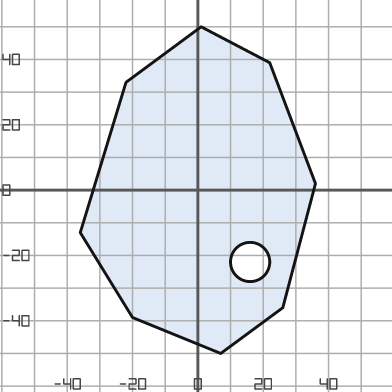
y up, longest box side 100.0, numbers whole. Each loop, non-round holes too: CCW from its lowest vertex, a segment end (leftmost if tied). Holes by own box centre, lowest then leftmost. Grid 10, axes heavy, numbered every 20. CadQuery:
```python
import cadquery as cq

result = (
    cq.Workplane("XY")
    .moveTo(7.0, -50.0)
    .lineTo(26.0, -36.0)
    .lineTo(36.0, 2.0)
    .lineTo(22.0, 39.0)
    .lineTo(1.0, 50.0)
    .lineTo(-22.0, 33.0)
    .lineTo(-36.0, -13.0)
    .lineTo(-20.0, -39.0)
    .close()
    .moveTo(16.0, -22.0)
    .circle(6.0)
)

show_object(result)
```